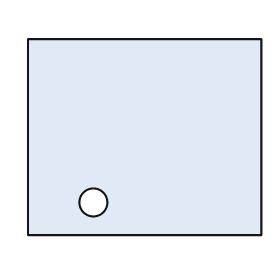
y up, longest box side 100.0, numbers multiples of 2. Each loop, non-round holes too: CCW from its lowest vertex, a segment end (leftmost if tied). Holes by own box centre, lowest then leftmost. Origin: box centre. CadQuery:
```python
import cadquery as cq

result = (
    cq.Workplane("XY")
    .moveTo(-50.0, -42.0)
    .lineTo(50.0, -42.0)
    .lineTo(50.0, 42.0)
    .lineTo(-50.0, 42.0)
    .close()
    .moveTo(-22.0, -28.0)
    .circle(6.0)
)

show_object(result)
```